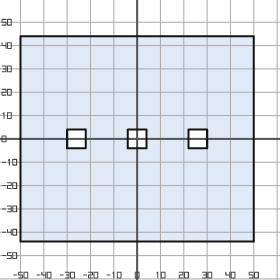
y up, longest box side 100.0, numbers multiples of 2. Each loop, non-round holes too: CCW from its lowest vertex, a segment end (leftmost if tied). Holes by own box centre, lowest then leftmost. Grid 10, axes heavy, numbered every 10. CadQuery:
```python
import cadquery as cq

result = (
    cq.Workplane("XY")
    .moveTo(-50.0, -44.0)
    .lineTo(50.0, -44.0)
    .lineTo(50.0, 44.0)
    .lineTo(-50.0, 44.0)
    .close()
    .moveTo(-30.0, -4.0)
    .lineTo(-22.0, -4.0)
    .lineTo(-22.0, 4.0)
    .lineTo(-30.0, 4.0)
    .close()
    .moveTo(-4.0, -4.0)
    .lineTo(4.0, -4.0)
    .lineTo(4.0, 4.0)
    .lineTo(-4.0, 4.0)
    .close()
    .moveTo(22.0, -4.0)
    .lineTo(30.0, -4.0)
    .lineTo(30.0, 4.0)
    .lineTo(22.0, 4.0)
    .close()
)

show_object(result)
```